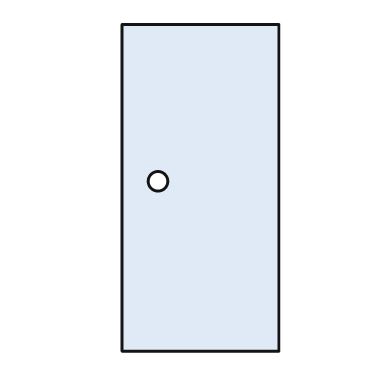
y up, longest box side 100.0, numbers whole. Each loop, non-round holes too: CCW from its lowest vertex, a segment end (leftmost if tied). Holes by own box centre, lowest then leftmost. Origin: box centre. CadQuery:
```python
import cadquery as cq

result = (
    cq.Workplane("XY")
    .moveTo(-24.0, -50.0)
    .lineTo(24.0, -50.0)
    .lineTo(24.0, 50.0)
    .lineTo(-24.0, 50.0)
    .close()
    .moveTo(-13.0, 2.0)
    .circle(3.0)
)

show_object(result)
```